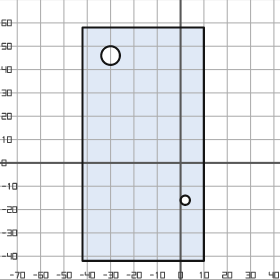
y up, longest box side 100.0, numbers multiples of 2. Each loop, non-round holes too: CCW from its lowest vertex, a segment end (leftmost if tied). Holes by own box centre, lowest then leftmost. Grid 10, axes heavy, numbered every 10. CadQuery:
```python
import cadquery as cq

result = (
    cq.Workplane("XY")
    .moveTo(-42.0, -42.0)
    .lineTo(10.0, -42.0)
    .lineTo(10.0, 58.0)
    .lineTo(-42.0, 58.0)
    .close()
    .moveTo(2.0, -16.0)
    .circle(2.0)
    .moveTo(-30.0, 46.0)
    .circle(4.0)
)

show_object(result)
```